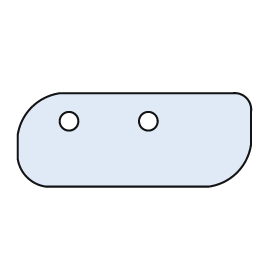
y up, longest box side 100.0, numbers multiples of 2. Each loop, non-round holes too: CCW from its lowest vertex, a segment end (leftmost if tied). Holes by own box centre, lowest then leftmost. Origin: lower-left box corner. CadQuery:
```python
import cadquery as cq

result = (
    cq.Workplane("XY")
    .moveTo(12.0, 0.0)
    .lineTo(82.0, 0.0)
    .threePointArc((94.0, 6.0), (100.0, 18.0))
    .lineTo(100.0, 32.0)
    .threePointArc((98.0, 38.0), (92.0, 40.0))
    .lineTo(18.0, 40.0)
    .threePointArc((6.0, 34.0), (0.0, 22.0))
    .lineTo(0.0, 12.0)
    .threePointArc((4.0, 4.0), (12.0, 0.0))
    .close()
    .moveTo(22.0, 28.0)
    .circle(4.0)
    .moveTo(56.0, 28.0)
    .circle(4.0)
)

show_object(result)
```